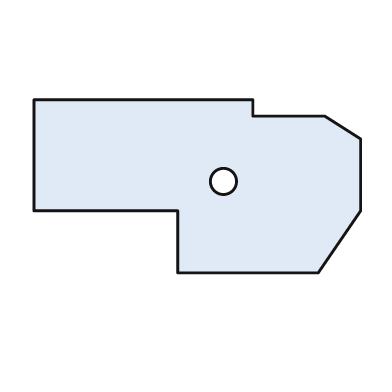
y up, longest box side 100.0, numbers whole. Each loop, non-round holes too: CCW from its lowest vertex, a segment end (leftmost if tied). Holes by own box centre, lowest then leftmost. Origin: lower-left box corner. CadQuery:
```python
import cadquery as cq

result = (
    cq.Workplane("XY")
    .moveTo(44.0, 0.0)
    .lineTo(87.0, 0.0)
    .lineTo(100.0, 19.0)
    .lineTo(100.0, 41.0)
    .lineTo(89.0, 48.0)
    .lineTo(67.0, 48.0)
    .lineTo(67.0, 53.0)
    .lineTo(0.0, 53.0)
    .lineTo(0.0, 19.0)
    .lineTo(44.0, 19.0)
    .close()
    .moveTo(58.0, 28.0)
    .circle(4.0)
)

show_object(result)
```